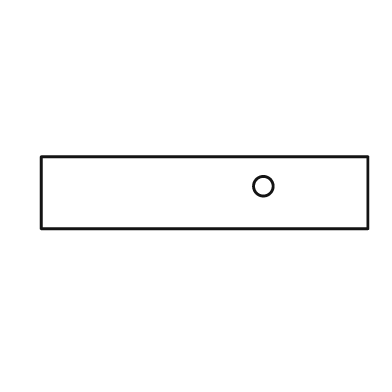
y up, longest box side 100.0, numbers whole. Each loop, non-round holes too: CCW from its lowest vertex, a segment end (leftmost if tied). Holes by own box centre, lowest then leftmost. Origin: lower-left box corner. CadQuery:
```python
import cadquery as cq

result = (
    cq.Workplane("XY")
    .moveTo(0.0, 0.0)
    .lineTo(100.0, 0.0)
    .lineTo(100.0, 22.0)
    .lineTo(0.0, 22.0)
    .close()
    .moveTo(68.0, 13.0)
    .circle(3.0)
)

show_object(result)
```